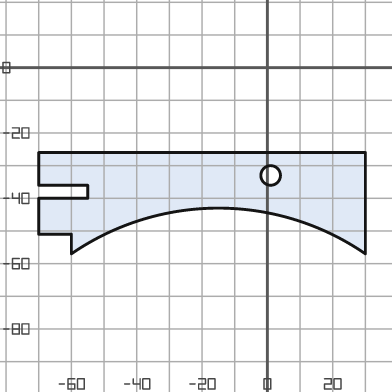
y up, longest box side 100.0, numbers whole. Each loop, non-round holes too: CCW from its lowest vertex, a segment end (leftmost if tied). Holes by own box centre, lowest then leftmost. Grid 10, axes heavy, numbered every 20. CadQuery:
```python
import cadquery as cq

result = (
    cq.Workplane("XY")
    .moveTo(-60.0, -57.0)
    .threePointArc((-15.0, -43.0), (30.0, -57.0))
    .lineTo(30.0, -26.0)
    .lineTo(-70.0, -26.0)
    .lineTo(-70.0, -36.0)
    .lineTo(-55.0, -36.0)
    .lineTo(-55.0, -40.0)
    .lineTo(-70.0, -40.0)
    .lineTo(-70.0, -51.0)
    .lineTo(-60.0, -51.0)
    .close()
    .moveTo(1.0, -33.0)
    .circle(3.0)
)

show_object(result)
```